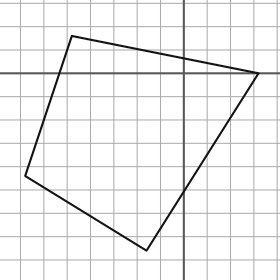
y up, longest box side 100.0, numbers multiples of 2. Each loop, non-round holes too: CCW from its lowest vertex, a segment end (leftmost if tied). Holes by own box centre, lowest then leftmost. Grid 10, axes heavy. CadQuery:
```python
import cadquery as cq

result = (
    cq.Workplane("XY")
    .moveTo(-16.0, -76.0)
    .lineTo(32.0, 0.0)
    .lineTo(-48.0, 16.0)
    .lineTo(-68.0, -44.0)
    .close()
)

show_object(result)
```